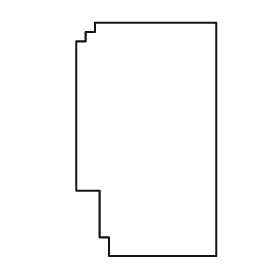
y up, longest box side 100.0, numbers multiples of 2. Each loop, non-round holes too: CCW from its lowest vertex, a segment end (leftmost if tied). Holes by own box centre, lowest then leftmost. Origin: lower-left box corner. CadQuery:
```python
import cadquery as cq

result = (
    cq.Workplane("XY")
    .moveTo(14.0, 0.0)
    .lineTo(60.0, 0.0)
    .lineTo(60.0, 100.0)
    .lineTo(8.0, 100.0)
    .lineTo(8.0, 96.0)
    .lineTo(4.0, 96.0)
    .lineTo(4.0, 92.0)
    .lineTo(0.0, 92.0)
    .lineTo(0.0, 28.0)
    .lineTo(10.0, 28.0)
    .lineTo(10.0, 8.0)
    .lineTo(14.0, 8.0)
    .close()
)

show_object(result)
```